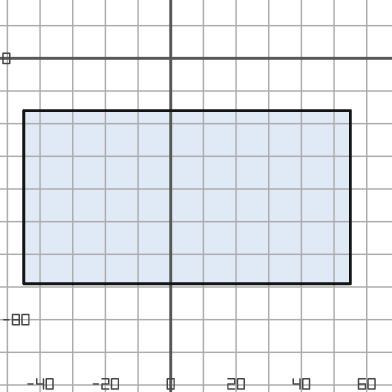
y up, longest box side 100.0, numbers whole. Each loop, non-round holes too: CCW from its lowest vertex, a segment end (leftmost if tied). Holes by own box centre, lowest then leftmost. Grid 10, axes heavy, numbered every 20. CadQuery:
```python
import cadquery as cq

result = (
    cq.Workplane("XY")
    .moveTo(-45.0, -69.0)
    .lineTo(55.0, -69.0)
    .lineTo(55.0, -16.0)
    .lineTo(-45.0, -16.0)
    .close()
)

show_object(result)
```